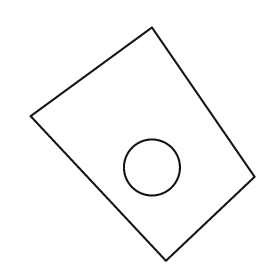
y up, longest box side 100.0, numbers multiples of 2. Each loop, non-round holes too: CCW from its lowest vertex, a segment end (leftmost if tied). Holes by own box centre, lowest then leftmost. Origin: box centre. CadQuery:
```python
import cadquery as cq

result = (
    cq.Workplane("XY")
    .moveTo(10.0, -50.0)
    .lineTo(48.0, -14.0)
    .lineTo(4.0, 50.0)
    .lineTo(-48.0, 12.0)
    .close()
    .moveTo(4.0, -10.0)
    .circle(12.0)
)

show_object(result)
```